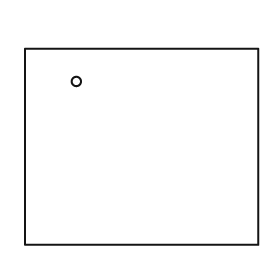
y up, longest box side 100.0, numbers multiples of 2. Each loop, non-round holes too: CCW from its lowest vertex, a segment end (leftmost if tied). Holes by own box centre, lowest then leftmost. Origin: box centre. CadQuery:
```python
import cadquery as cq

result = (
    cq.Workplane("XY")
    .moveTo(-50.0, -42.0)
    .lineTo(50.0, -42.0)
    .lineTo(50.0, 42.0)
    .lineTo(-50.0, 42.0)
    .close()
    .moveTo(-28.0, 28.0)
    .circle(2.0)
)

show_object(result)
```